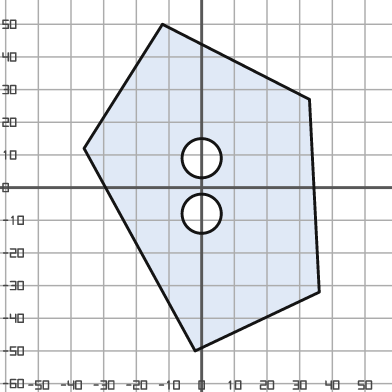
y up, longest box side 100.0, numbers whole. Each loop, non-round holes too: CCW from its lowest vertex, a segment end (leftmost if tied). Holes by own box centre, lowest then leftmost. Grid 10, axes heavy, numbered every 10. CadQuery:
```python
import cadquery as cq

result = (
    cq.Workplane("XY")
    .moveTo(-2.0, -50.0)
    .lineTo(36.0, -32.0)
    .lineTo(33.0, 27.0)
    .lineTo(-12.0, 50.0)
    .lineTo(-36.0, 12.0)
    .close()
    .moveTo(0.0, -8.0)
    .circle(6.0)
    .moveTo(0.0, 9.0)
    .circle(6.0)
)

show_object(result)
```